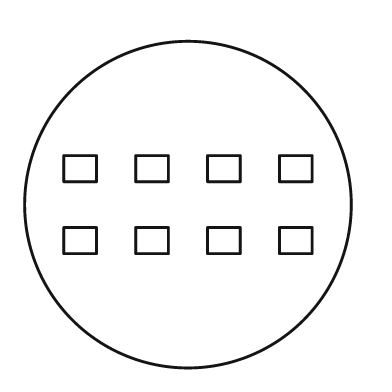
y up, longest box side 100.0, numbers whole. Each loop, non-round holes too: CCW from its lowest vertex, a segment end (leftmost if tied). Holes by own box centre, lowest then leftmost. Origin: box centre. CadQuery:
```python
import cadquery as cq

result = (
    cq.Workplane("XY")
    .moveTo(0.0, 0.0)
    .circle(50.0)
    .moveTo(-38.0, -15.0)
    .lineTo(-28.0, -15.0)
    .lineTo(-28.0, -7.0)
    .lineTo(-38.0, -7.0)
    .close()
    .moveTo(-16.0, -15.0)
    .lineTo(-6.0, -15.0)
    .lineTo(-6.0, -7.0)
    .lineTo(-16.0, -7.0)
    .close()
    .moveTo(6.0, -15.0)
    .lineTo(16.0, -15.0)
    .lineTo(16.0, -7.0)
    .lineTo(6.0, -7.0)
    .close()
    .moveTo(28.0, -15.0)
    .lineTo(38.0, -15.0)
    .lineTo(38.0, -7.0)
    .lineTo(28.0, -7.0)
    .close()
    .moveTo(-38.0, 7.0)
    .lineTo(-28.0, 7.0)
    .lineTo(-28.0, 15.0)
    .lineTo(-38.0, 15.0)
    .close()
    .moveTo(-16.0, 7.0)
    .lineTo(-6.0, 7.0)
    .lineTo(-6.0, 15.0)
    .lineTo(-16.0, 15.0)
    .close()
    .moveTo(6.0, 7.0)
    .lineTo(16.0, 7.0)
    .lineTo(16.0, 15.0)
    .lineTo(6.0, 15.0)
    .close()
    .moveTo(28.0, 7.0)
    .lineTo(38.0, 7.0)
    .lineTo(38.0, 15.0)
    .lineTo(28.0, 15.0)
    .close()
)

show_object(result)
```